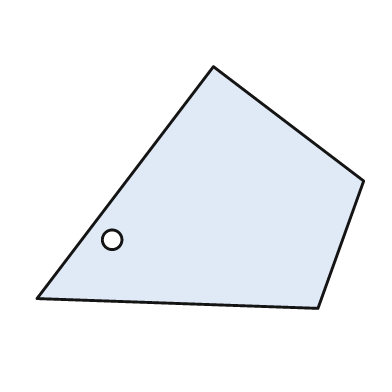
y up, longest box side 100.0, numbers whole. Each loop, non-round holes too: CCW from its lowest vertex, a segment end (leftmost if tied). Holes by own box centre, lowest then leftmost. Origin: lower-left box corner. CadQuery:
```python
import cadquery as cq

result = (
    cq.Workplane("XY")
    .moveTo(86.0, 0.0)
    .lineTo(100.0, 39.0)
    .lineTo(54.0, 74.0)
    .lineTo(0.0, 3.0)
    .close()
    .moveTo(23.0, 21.0)
    .circle(3.0)
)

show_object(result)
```